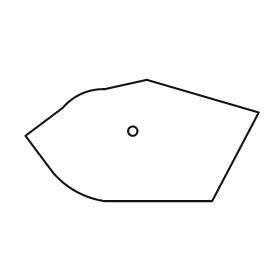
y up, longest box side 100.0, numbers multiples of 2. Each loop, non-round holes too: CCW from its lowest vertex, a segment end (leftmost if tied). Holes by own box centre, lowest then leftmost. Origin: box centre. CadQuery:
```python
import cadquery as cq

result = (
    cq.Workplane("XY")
    .moveTo(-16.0, -26.0)
    .lineTo(30.0, -26.0)
    .lineTo(50.0, 12.0)
    .lineTo(2.0, 26.0)
    .lineTo(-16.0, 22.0)
    .threePointArc((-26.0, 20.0), (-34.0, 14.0))
    .lineTo(-50.0, 2.0)
    .lineTo(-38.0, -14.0)
    .threePointArc((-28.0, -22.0), (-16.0, -26.0))
    .close()
    .moveTo(-4.0, 4.0)
    .circle(2.0)
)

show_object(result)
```